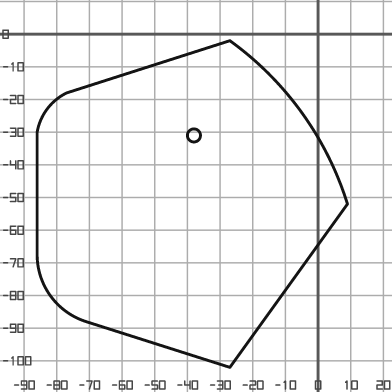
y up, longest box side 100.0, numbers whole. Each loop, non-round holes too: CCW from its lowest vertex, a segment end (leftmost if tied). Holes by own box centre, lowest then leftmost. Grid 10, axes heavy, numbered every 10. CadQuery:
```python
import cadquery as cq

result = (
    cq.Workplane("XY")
    .moveTo(-27.0, -102.0)
    .lineTo(9.0, -52.0)
    .threePointArc((-5.0, -24.0), (-27.0, -2.0))
    .lineTo(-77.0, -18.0)
    .threePointArc((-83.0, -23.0), (-86.0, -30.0))
    .lineTo(-86.0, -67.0)
    .threePointArc((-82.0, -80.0), (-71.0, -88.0))
    .close()
    .moveTo(-38.0, -31.0)
    .circle(2.0)
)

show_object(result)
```